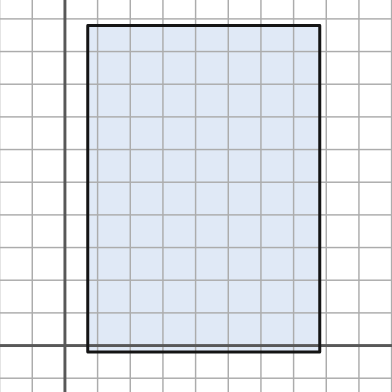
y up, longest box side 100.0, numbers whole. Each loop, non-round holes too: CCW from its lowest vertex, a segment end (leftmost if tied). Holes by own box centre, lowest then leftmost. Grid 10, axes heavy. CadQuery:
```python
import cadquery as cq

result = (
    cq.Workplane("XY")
    .moveTo(7.0, -2.0)
    .lineTo(78.0, -2.0)
    .lineTo(78.0, 98.0)
    .lineTo(7.0, 98.0)
    .close()
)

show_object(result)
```